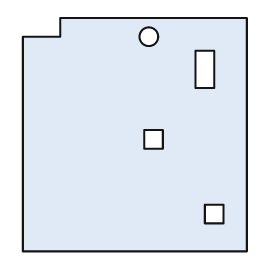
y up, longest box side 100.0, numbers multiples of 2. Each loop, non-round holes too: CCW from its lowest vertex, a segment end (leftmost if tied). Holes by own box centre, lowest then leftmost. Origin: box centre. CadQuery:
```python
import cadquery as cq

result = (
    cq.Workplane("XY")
    .moveTo(-48.0, -50.0)
    .lineTo(48.0, -50.0)
    .lineTo(48.0, 50.0)
    .lineTo(-32.0, 50.0)
    .lineTo(-32.0, 42.0)
    .lineTo(-48.0, 42.0)
    .close()
    .moveTo(30.0, -38.0)
    .lineTo(38.0, -38.0)
    .lineTo(38.0, -30.0)
    .lineTo(30.0, -30.0)
    .close()
    .moveTo(4.0, -6.0)
    .lineTo(12.0, -6.0)
    .lineTo(12.0, 2.0)
    .lineTo(4.0, 2.0)
    .close()
    .moveTo(26.0, 20.0)
    .lineTo(34.0, 20.0)
    .lineTo(34.0, 36.0)
    .lineTo(26.0, 36.0)
    .close()
    .moveTo(6.0, 42.0)
    .circle(4.0)
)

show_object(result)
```